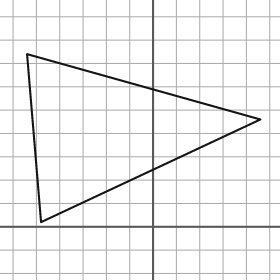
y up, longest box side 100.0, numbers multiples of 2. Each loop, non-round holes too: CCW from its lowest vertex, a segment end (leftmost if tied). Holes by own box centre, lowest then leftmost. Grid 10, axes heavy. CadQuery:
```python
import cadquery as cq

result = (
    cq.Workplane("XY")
    .moveTo(-48.0, 2.0)
    .lineTo(46.0, 46.0)
    .lineTo(-54.0, 74.0)
    .close()
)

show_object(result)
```